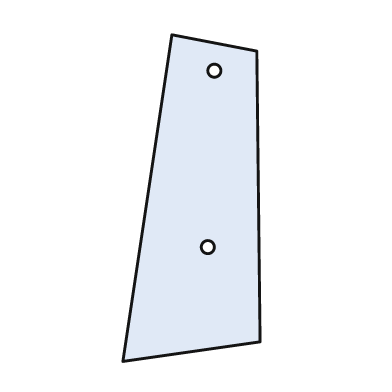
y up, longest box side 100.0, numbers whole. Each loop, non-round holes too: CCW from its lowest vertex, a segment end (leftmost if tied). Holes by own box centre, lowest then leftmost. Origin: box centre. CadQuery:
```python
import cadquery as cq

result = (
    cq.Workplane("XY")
    .moveTo(-21.0, -50.0)
    .lineTo(21.0, -44.0)
    .lineTo(20.0, 45.0)
    .lineTo(-6.0, 50.0)
    .close()
    .moveTo(5.0, -15.0)
    .circle(2.0)
    .moveTo(7.0, 39.0)
    .circle(2.0)
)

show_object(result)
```